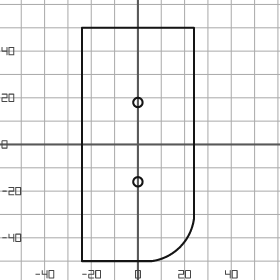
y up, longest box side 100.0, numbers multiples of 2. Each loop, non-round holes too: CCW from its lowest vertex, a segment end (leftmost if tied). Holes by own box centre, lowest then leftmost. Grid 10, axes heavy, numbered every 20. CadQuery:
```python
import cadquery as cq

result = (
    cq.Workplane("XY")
    .moveTo(-24.0, -50.0)
    .lineTo(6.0, -50.0)
    .threePointArc((18.0, -44.0), (24.0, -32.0))
    .lineTo(24.0, 50.0)
    .lineTo(-24.0, 50.0)
    .close()
    .moveTo(0.0, -16.0)
    .circle(2.0)
    .moveTo(0.0, 18.0)
    .circle(2.0)
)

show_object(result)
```